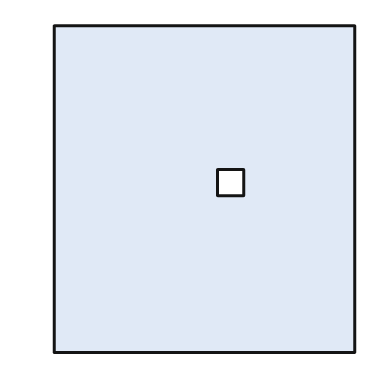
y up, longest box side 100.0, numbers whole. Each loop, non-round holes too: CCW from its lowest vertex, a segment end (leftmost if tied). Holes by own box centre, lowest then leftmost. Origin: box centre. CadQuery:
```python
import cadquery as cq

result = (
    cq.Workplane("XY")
    .moveTo(-46.0, -50.0)
    .lineTo(46.0, -50.0)
    .lineTo(46.0, 50.0)
    .lineTo(-46.0, 50.0)
    .close()
    .moveTo(4.0, -2.0)
    .lineTo(12.0, -2.0)
    .lineTo(12.0, 6.0)
    .lineTo(4.0, 6.0)
    .close()
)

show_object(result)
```